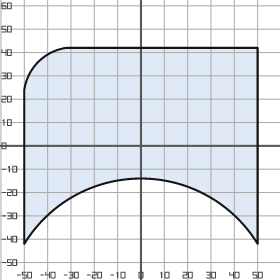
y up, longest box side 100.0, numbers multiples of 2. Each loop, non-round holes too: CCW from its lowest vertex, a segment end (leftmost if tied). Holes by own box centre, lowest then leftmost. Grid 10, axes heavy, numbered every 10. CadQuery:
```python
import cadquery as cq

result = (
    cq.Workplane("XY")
    .moveTo(-50.0, -42.0)
    .threePointArc((0.0, -14.0), (50.0, -42.0))
    .lineTo(50.0, 42.0)
    .lineTo(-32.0, 42.0)
    .threePointArc((-44.0, 36.0), (-50.0, 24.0))
    .close()
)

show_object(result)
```